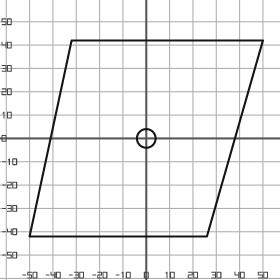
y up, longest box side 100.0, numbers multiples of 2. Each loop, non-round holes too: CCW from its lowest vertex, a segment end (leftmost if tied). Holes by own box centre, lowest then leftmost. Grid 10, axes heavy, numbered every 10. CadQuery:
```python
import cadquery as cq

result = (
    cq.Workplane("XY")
    .moveTo(-50.0, -42.0)
    .lineTo(26.0, -42.0)
    .lineTo(50.0, 42.0)
    .lineTo(-32.0, 42.0)
    .close()
    .moveTo(0.0, 0.0)
    .circle(4.0)
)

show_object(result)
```